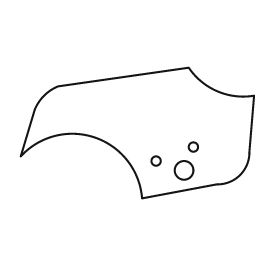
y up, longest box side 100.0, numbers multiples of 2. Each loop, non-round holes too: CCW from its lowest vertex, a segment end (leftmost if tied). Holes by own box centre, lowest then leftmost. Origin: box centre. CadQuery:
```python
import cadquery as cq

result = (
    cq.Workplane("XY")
    .moveTo(2.0, -28.0)
    .lineTo(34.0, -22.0)
    .threePointArc((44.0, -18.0), (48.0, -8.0))
    .lineTo(50.0, 16.0)
    .threePointArc((34.0, 18.0), (22.0, 28.0))
    .lineTo(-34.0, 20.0)
    .threePointArc((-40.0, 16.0), (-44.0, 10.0))
    .lineTo(-50.0, -10.0)
    .threePointArc((-18.0, -2.0), (2.0, -28.0))
    .close()
    .moveTo(20.0, -16.0)
    .circle(4.0)
    .moveTo(8.0, -12.0)
    .circle(2.0)
    .moveTo(24.0, -6.0)
    .circle(2.0)
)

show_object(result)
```